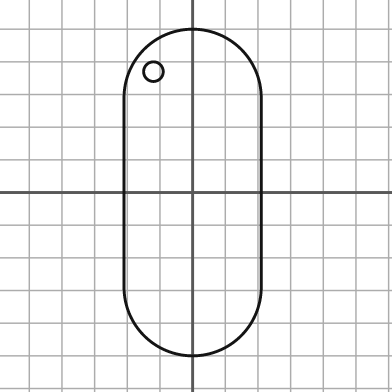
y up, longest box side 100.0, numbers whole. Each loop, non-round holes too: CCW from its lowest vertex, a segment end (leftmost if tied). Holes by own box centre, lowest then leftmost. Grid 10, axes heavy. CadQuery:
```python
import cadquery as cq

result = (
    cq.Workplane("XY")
    .moveTo(-21.0, -29.0)
    .threePointArc((0.0, -50.0), (21.0, -29.0))
    .lineTo(21.0, 29.0)
    .threePointArc((0.0, 50.0), (-21.0, 29.0))
    .close()
    .moveTo(-12.0, 37.0)
    .circle(3.0)
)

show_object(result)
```